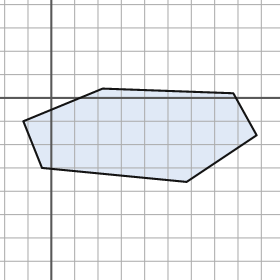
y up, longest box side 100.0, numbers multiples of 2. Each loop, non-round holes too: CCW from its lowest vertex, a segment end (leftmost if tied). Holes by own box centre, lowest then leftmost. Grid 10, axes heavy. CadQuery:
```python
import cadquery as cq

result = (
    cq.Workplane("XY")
    .moveTo(58.0, -36.0)
    .lineTo(88.0, -16.0)
    .lineTo(78.0, 2.0)
    .lineTo(22.0, 4.0)
    .lineTo(-12.0, -10.0)
    .lineTo(-4.0, -30.0)
    .close()
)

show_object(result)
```